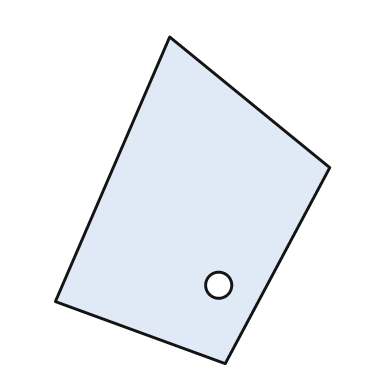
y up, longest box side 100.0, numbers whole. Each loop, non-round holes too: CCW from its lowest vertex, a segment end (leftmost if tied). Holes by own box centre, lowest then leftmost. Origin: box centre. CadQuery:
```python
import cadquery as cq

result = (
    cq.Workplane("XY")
    .moveTo(10.0, -50.0)
    .lineTo(42.0, 10.0)
    .lineTo(-7.0, 50.0)
    .lineTo(-42.0, -31.0)
    .close()
    .moveTo(8.0, -26.0)
    .circle(4.0)
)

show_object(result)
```